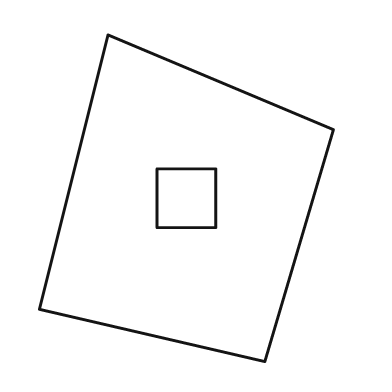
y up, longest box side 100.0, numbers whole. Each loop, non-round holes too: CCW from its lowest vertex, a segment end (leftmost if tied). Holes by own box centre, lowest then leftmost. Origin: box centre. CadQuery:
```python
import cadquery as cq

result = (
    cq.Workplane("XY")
    .moveTo(24.0, -50.0)
    .lineTo(45.0, 21.0)
    .lineTo(-24.0, 50.0)
    .lineTo(-45.0, -34.0)
    .close()
    .moveTo(-9.0, -9.0)
    .lineTo(9.0, -9.0)
    .lineTo(9.0, 9.0)
    .lineTo(-9.0, 9.0)
    .close()
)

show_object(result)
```